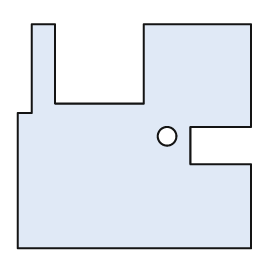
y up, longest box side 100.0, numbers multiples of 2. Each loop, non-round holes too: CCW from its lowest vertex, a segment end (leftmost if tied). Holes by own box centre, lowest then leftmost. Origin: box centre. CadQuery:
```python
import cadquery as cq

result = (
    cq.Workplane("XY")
    .moveTo(-50.0, -48.0)
    .lineTo(50.0, -48.0)
    .lineTo(50.0, -12.0)
    .lineTo(24.0, -12.0)
    .lineTo(24.0, 4.0)
    .lineTo(50.0, 4.0)
    .lineTo(50.0, 48.0)
    .lineTo(4.0, 48.0)
    .lineTo(4.0, 14.0)
    .lineTo(-34.0, 14.0)
    .lineTo(-34.0, 48.0)
    .lineTo(-44.0, 48.0)
    .lineTo(-44.0, 10.0)
    .lineTo(-50.0, 10.0)
    .close()
    .moveTo(14.0, 0.0)
    .circle(4.0)
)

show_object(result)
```